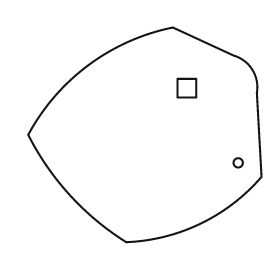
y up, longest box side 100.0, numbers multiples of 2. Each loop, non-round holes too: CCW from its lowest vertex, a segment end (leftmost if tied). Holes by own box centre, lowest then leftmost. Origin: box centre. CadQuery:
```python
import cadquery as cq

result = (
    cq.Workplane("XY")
    .moveTo(-8.0, -46.0)
    .threePointArc((24.0, -38.0), (50.0, -18.0))
    .lineTo(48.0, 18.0)
    .threePointArc((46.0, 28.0), (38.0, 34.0))
    .lineTo(12.0, 46.0)
    .threePointArc((-24.0, 30.0), (-50.0, 0.0))
    .threePointArc((-32.0, -26.0), (-8.0, -46.0))
    .close()
    .moveTo(40.0, -12.0)
    .circle(2.0)
    .moveTo(14.0, 16.0)
    .lineTo(22.0, 16.0)
    .lineTo(22.0, 24.0)
    .lineTo(14.0, 24.0)
    .close()
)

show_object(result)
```